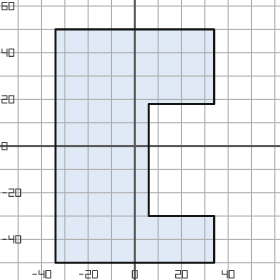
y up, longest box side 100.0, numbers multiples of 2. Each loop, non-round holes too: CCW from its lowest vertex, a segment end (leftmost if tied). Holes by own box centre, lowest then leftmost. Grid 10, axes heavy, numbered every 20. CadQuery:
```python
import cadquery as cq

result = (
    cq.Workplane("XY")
    .moveTo(-34.0, -50.0)
    .lineTo(34.0, -50.0)
    .lineTo(34.0, -30.0)
    .lineTo(6.0, -30.0)
    .lineTo(6.0, 18.0)
    .lineTo(34.0, 18.0)
    .lineTo(34.0, 50.0)
    .lineTo(-34.0, 50.0)
    .close()
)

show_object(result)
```